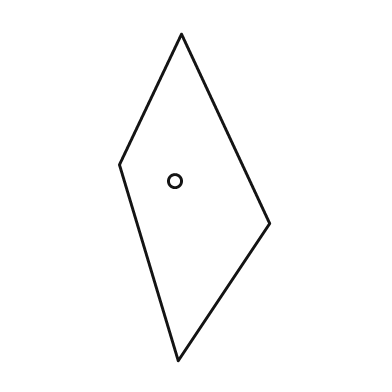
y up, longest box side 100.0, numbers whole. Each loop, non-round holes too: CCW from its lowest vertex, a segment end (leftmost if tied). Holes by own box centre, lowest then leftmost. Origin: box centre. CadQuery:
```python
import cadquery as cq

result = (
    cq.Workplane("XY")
    .moveTo(-5.0, -50.0)
    .lineTo(23.0, -8.0)
    .lineTo(-4.0, 50.0)
    .lineTo(-23.0, 10.0)
    .close()
    .moveTo(-6.0, 5.0)
    .circle(2.0)
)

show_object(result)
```